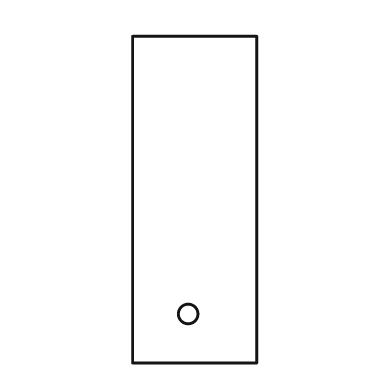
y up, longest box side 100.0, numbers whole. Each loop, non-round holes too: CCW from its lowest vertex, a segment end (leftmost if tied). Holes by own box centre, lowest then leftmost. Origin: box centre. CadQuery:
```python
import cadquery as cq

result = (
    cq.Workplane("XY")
    .moveTo(-19.0, -50.0)
    .lineTo(19.0, -50.0)
    .lineTo(19.0, 50.0)
    .lineTo(-19.0, 50.0)
    .close()
    .moveTo(-2.0, -35.0)
    .circle(3.0)
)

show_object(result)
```